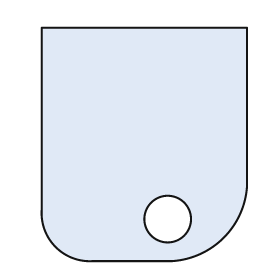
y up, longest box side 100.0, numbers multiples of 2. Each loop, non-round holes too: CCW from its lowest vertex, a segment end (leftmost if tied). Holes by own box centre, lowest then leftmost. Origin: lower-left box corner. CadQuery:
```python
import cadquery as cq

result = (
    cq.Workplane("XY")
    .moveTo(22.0, 0.0)
    .lineTo(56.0, 0.0)
    .threePointArc((78.0, 10.0), (88.0, 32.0))
    .lineTo(88.0, 100.0)
    .lineTo(0.0, 100.0)
    .lineTo(0.0, 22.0)
    .threePointArc((6.0, 6.0), (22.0, 0.0))
    .close()
    .moveTo(54.0, 18.0)
    .circle(10.0)
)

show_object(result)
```